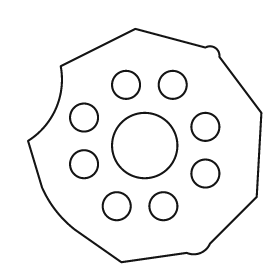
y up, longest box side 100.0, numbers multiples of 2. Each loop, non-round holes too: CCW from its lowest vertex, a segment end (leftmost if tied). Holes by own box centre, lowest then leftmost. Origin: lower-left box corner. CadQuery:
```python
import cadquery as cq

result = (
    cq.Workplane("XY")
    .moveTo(40.0, 0.0)
    .lineTo(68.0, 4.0)
    .threePointArc((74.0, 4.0), (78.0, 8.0))
    .lineTo(98.0, 28.0)
    .lineTo(100.0, 64.0)
    .lineTo(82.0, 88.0)
    .threePointArc((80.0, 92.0), (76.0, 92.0))
    .lineTo(46.0, 100.0)
    .lineTo(14.0, 84.0)
    .threePointArc((12.0, 66.0), (0.0, 52.0))
    .lineTo(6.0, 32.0)
    .threePointArc((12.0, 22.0), (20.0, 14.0))
    .close()
    .moveTo(38.0, 24.0)
    .circle(6.0)
    .moveTo(58.0, 24.0)
    .circle(6.0)
    .moveTo(76.0, 38.0)
    .circle(6.0)
    .moveTo(24.0, 42.0)
    .circle(6.0)
    .moveTo(50.0, 50.0)
    .circle(14.0)
    .moveTo(76.0, 58.0)
    .circle(6.0)
    .moveTo(24.0, 62.0)
    .circle(6.0)
    .moveTo(42.0, 76.0)
    .circle(6.0)
    .moveTo(62.0, 76.0)
    .circle(6.0)
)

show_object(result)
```